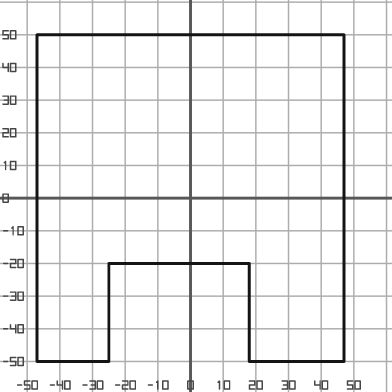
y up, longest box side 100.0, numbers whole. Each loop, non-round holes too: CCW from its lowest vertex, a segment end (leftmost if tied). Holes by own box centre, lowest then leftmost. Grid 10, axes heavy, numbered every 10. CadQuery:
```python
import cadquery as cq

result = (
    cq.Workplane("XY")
    .moveTo(-47.0, -50.0)
    .lineTo(-25.0, -50.0)
    .lineTo(-25.0, -20.0)
    .lineTo(18.0, -20.0)
    .lineTo(18.0, -50.0)
    .lineTo(47.0, -50.0)
    .lineTo(47.0, 50.0)
    .lineTo(-47.0, 50.0)
    .close()
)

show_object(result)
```